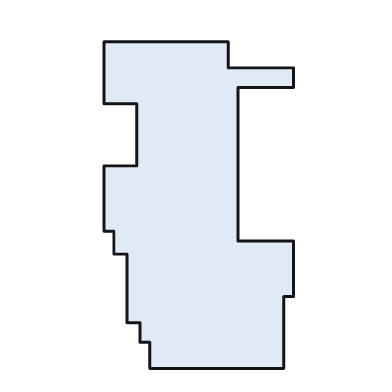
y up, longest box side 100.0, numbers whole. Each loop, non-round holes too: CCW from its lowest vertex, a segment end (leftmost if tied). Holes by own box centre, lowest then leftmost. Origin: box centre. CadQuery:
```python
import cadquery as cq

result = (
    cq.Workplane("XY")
    .moveTo(-15.0, -50.0)
    .lineTo(26.0, -50.0)
    .lineTo(26.0, -28.0)
    .lineTo(29.0, -28.0)
    .lineTo(29.0, -11.0)
    .lineTo(12.0, -11.0)
    .lineTo(12.0, 36.0)
    .lineTo(29.0, 36.0)
    .lineTo(29.0, 42.0)
    .lineTo(9.0, 42.0)
    .lineTo(9.0, 50.0)
    .lineTo(-29.0, 50.0)
    .lineTo(-29.0, 31.0)
    .lineTo(-19.0, 31.0)
    .lineTo(-19.0, 12.0)
    .lineTo(-29.0, 12.0)
    .lineTo(-29.0, -8.0)
    .lineTo(-26.0, -8.0)
    .lineTo(-26.0, -15.0)
    .lineTo(-22.0, -15.0)
    .lineTo(-22.0, -36.0)
    .lineTo(-18.0, -36.0)
    .lineTo(-18.0, -42.0)
    .lineTo(-15.0, -42.0)
    .close()
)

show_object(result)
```